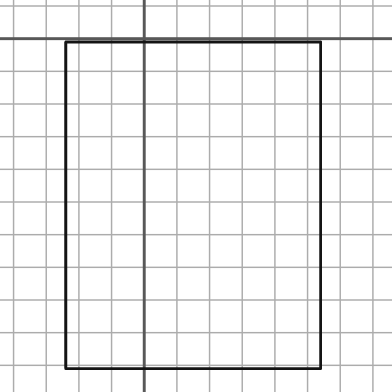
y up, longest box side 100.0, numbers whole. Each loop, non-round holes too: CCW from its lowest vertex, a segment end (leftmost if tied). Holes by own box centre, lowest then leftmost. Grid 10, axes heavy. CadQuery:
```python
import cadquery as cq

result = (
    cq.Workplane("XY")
    .moveTo(-24.0, -101.0)
    .lineTo(54.0, -101.0)
    .lineTo(54.0, -1.0)
    .lineTo(-24.0, -1.0)
    .close()
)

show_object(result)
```